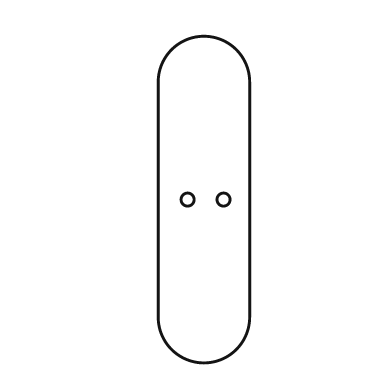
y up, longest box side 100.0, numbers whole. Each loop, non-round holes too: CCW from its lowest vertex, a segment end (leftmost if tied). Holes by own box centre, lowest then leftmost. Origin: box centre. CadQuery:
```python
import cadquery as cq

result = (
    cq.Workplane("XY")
    .moveTo(-14.0, -36.0)
    .threePointArc((0.0, -50.0), (14.0, -36.0))
    .lineTo(14.0, 36.0)
    .threePointArc((0.0, 50.0), (-14.0, 36.0))
    .close()
    .moveTo(-5.0, 0.0)
    .circle(2.0)
    .moveTo(6.0, 0.0)
    .circle(2.0)
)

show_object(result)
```